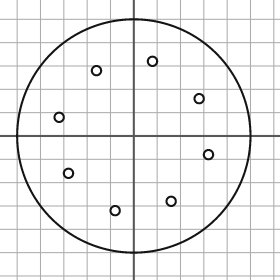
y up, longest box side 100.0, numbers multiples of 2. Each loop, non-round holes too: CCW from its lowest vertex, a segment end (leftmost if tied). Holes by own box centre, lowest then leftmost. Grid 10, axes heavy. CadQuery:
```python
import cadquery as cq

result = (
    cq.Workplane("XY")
    .moveTo(0.0, 0.0)
    .circle(50.0)
    .moveTo(-8.0, -32.0)
    .circle(2.0)
    .moveTo(16.0, -28.0)
    .circle(2.0)
    .moveTo(-28.0, -16.0)
    .circle(2.0)
    .moveTo(32.0, -8.0)
    .circle(2.0)
    .moveTo(-32.0, 8.0)
    .circle(2.0)
    .moveTo(28.0, 16.0)
    .circle(2.0)
    .moveTo(-16.0, 28.0)
    .circle(2.0)
    .moveTo(8.0, 32.0)
    .circle(2.0)
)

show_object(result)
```